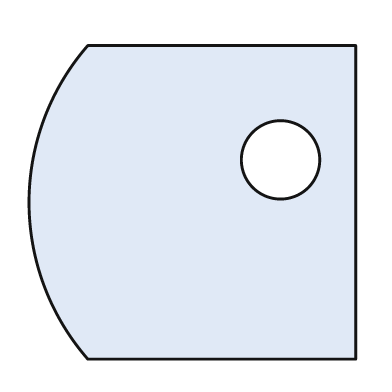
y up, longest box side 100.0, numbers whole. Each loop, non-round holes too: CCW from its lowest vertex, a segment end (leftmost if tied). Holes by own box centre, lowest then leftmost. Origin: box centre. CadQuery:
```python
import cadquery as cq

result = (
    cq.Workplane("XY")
    .moveTo(-32.0, -48.0)
    .lineTo(50.0, -48.0)
    .lineTo(50.0, 48.0)
    .lineTo(-32.0, 48.0)
    .threePointArc((-50.0, 0.0), (-32.0, -48.0))
    .close()
    .moveTo(27.0, 13.0)
    .circle(12.0)
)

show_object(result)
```